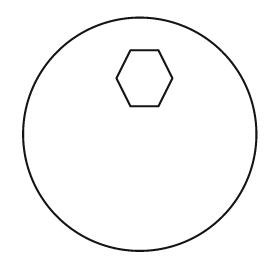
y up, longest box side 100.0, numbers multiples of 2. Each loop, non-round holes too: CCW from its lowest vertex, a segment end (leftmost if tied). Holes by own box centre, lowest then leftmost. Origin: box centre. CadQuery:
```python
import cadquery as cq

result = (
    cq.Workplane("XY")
    .moveTo(0.0, 0.0)
    .circle(50.0)
    .moveTo(-4.0, 12.0)
    .lineTo(8.0, 12.0)
    .lineTo(14.0, 24.0)
    .lineTo(8.0, 36.0)
    .lineTo(-4.0, 36.0)
    .lineTo(-10.0, 24.0)
    .close()
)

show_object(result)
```